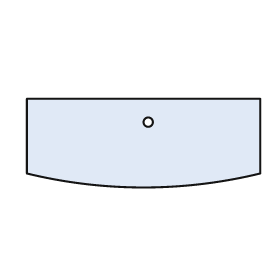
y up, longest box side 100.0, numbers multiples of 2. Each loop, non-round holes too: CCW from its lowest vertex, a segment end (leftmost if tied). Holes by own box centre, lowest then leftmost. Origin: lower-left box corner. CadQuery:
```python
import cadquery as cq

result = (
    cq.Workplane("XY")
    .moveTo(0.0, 6.0)
    .threePointArc((50.0, 0.0), (100.0, 6.0))
    .lineTo(100.0, 38.0)
    .lineTo(0.0, 38.0)
    .close()
    .moveTo(52.0, 28.0)
    .circle(2.0)
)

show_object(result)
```